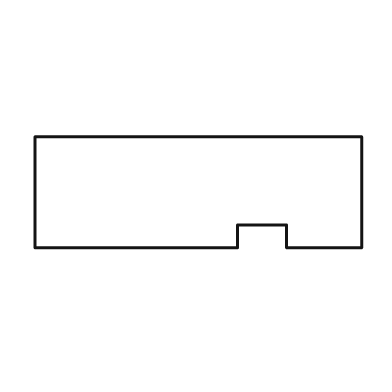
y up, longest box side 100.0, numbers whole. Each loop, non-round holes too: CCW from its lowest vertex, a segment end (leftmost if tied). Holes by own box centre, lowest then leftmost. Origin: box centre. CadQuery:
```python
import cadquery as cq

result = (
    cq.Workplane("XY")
    .moveTo(-50.0, -17.0)
    .lineTo(12.0, -17.0)
    .lineTo(12.0, -10.0)
    .lineTo(27.0, -10.0)
    .lineTo(27.0, -17.0)
    .lineTo(50.0, -17.0)
    .lineTo(50.0, 17.0)
    .lineTo(-50.0, 17.0)
    .close()
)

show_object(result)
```